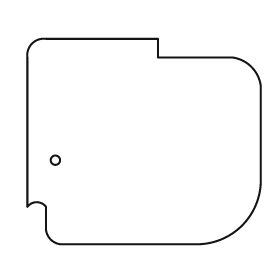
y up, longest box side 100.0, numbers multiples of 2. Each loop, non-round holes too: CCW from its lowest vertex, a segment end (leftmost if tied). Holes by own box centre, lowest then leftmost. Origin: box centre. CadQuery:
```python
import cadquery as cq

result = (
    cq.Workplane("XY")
    .moveTo(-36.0, -44.0)
    .lineTo(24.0, -44.0)
    .threePointArc((42.0, -36.0), (50.0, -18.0))
    .lineTo(50.0, 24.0)
    .threePointArc((46.0, 32.0), (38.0, 36.0))
    .lineTo(6.0, 36.0)
    .lineTo(6.0, 44.0)
    .lineTo(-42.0, 44.0)
    .threePointArc((-48.0, 42.0), (-50.0, 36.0))
    .lineTo(-50.0, -28.0)
    .threePointArc((-46.0, -26.0), (-42.0, -28.0))
    .lineTo(-42.0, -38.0)
    .threePointArc((-40.0, -42.0), (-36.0, -44.0))
    .close()
    .moveTo(-38.0, -8.0)
    .circle(2.0)
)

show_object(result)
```